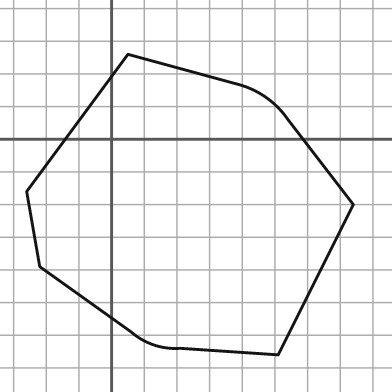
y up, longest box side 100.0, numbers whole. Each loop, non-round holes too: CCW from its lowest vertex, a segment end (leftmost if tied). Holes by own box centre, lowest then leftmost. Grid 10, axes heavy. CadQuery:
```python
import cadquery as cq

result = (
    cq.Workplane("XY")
    .moveTo(51.0, -66.0)
    .lineTo(74.0, -20.0)
    .lineTo(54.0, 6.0)
    .threePointArc((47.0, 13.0), (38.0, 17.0))
    .lineTo(5.0, 26.0)
    .lineTo(-26.0, -16.0)
    .lineTo(-22.0, -39.0)
    .lineTo(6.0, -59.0)
    .threePointArc((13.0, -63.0), (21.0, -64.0))
    .close()
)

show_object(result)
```